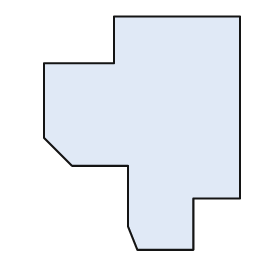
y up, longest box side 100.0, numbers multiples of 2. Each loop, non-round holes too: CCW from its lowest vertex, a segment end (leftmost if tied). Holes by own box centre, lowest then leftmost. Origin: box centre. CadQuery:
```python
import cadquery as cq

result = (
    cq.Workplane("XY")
    .moveTo(-2.0, -50.0)
    .lineTo(22.0, -50.0)
    .lineTo(22.0, -28.0)
    .lineTo(42.0, -28.0)
    .lineTo(42.0, 50.0)
    .lineTo(-12.0, 50.0)
    .lineTo(-12.0, 30.0)
    .lineTo(-42.0, 30.0)
    .lineTo(-42.0, -2.0)
    .lineTo(-30.0, -14.0)
    .lineTo(-6.0, -14.0)
    .lineTo(-6.0, -40.0)
    .close()
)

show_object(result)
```